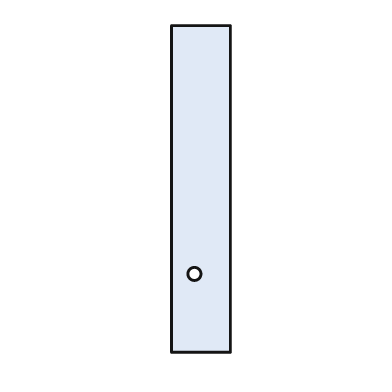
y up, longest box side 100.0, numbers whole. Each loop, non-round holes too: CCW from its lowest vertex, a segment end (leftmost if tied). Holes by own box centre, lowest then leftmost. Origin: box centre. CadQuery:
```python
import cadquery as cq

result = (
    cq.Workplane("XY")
    .moveTo(-9.0, -50.0)
    .lineTo(9.0, -50.0)
    .lineTo(9.0, 50.0)
    .lineTo(-9.0, 50.0)
    .close()
    .moveTo(-2.0, -26.0)
    .circle(2.0)
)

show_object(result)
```